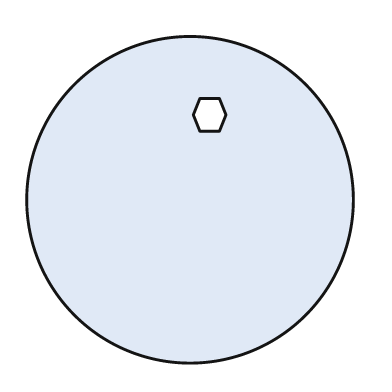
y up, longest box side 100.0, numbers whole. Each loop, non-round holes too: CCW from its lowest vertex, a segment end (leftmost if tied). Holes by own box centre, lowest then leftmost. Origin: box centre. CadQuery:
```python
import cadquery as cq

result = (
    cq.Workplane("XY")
    .moveTo(0.0, 0.0)
    .circle(50.0)
    .moveTo(3.0, 21.0)
    .lineTo(9.0, 21.0)
    .lineTo(11.0, 26.0)
    .lineTo(9.0, 31.0)
    .lineTo(3.0, 31.0)
    .lineTo(1.0, 26.0)
    .close()
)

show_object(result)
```